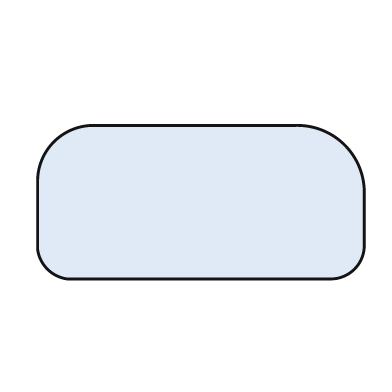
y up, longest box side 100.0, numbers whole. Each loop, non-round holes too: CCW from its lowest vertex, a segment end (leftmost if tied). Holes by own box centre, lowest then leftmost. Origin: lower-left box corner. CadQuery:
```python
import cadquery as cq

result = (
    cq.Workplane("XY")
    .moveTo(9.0, 0.0)
    .lineTo(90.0, 0.0)
    .threePointArc((97.0, 3.0), (100.0, 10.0))
    .lineTo(100.0, 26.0)
    .threePointArc((94.0, 41.0), (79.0, 47.0))
    .lineTo(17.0, 47.0)
    .threePointArc((5.0, 42.0), (0.0, 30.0))
    .lineTo(0.0, 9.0)
    .threePointArc((3.0, 3.0), (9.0, 0.0))
    .close()
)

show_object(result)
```